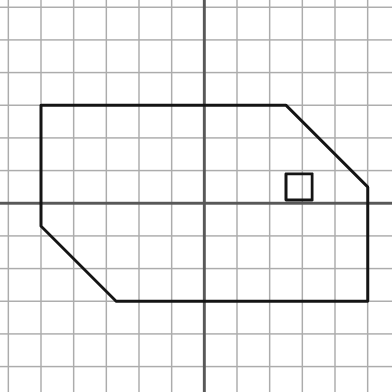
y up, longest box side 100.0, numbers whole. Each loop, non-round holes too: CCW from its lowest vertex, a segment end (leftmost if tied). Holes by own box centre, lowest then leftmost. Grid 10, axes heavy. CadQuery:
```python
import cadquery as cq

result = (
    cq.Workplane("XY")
    .moveTo(-27.0, -30.0)
    .lineTo(50.0, -30.0)
    .lineTo(50.0, 5.0)
    .lineTo(25.0, 30.0)
    .lineTo(-50.0, 30.0)
    .lineTo(-50.0, -7.0)
    .close()
    .moveTo(25.0, 1.0)
    .lineTo(33.0, 1.0)
    .lineTo(33.0, 9.0)
    .lineTo(25.0, 9.0)
    .close()
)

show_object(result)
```